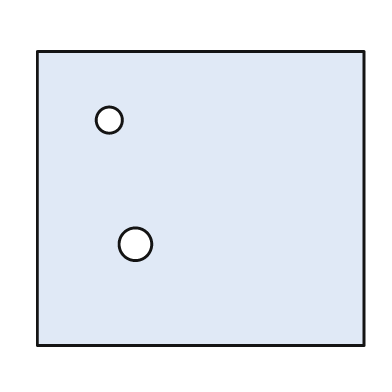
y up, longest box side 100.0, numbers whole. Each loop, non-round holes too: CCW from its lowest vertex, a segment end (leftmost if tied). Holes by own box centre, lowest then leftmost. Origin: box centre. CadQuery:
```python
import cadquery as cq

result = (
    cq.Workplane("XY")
    .moveTo(-50.0, -45.0)
    .lineTo(50.0, -45.0)
    .lineTo(50.0, 45.0)
    .lineTo(-50.0, 45.0)
    .close()
    .moveTo(-20.0, -14.0)
    .circle(5.0)
    .moveTo(-28.0, 24.0)
    .circle(4.0)
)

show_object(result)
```